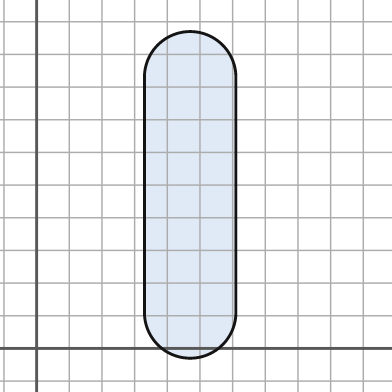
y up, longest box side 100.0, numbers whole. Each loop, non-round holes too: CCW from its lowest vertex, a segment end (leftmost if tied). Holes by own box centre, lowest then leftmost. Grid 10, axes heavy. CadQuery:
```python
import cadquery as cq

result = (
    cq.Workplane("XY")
    .moveTo(33.0, 11.0)
    .threePointArc((47.0, -3.0), (61.0, 11.0))
    .lineTo(61.0, 83.0)
    .threePointArc((47.0, 97.0), (33.0, 83.0))
    .close()
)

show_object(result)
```